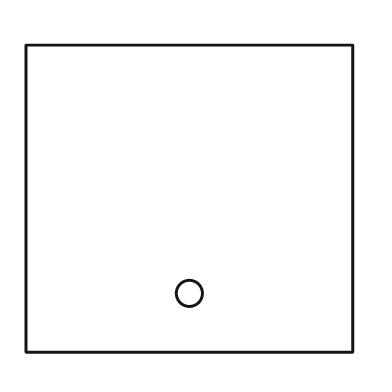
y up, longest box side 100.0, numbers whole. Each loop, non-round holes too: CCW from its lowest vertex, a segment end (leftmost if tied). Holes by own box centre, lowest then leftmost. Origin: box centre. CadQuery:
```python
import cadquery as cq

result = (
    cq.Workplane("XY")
    .moveTo(-50.0, -47.0)
    .lineTo(50.0, -47.0)
    .lineTo(50.0, 47.0)
    .lineTo(-50.0, 47.0)
    .close()
    .moveTo(0.0, -29.0)
    .circle(4.0)
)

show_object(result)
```